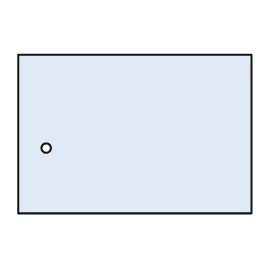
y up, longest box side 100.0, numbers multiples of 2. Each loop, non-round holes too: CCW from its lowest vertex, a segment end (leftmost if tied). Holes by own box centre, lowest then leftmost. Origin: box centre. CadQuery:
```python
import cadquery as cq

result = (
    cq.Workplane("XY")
    .moveTo(-50.0, -34.0)
    .lineTo(50.0, -34.0)
    .lineTo(50.0, 34.0)
    .lineTo(-50.0, 34.0)
    .close()
    .moveTo(-38.0, -6.0)
    .circle(2.0)
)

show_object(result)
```